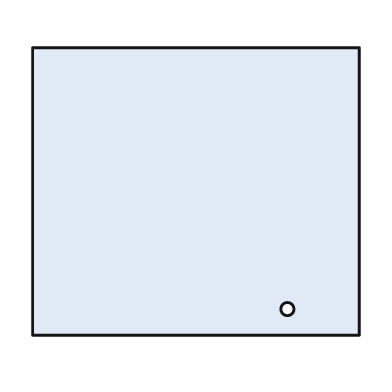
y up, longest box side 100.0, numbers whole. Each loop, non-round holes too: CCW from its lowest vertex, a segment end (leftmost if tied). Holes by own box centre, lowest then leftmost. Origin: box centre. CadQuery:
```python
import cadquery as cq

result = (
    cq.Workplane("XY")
    .moveTo(-50.0, -44.0)
    .lineTo(50.0, -44.0)
    .lineTo(50.0, 44.0)
    .lineTo(-50.0, 44.0)
    .close()
    .moveTo(28.0, -36.0)
    .circle(2.0)
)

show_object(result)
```